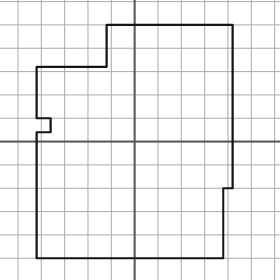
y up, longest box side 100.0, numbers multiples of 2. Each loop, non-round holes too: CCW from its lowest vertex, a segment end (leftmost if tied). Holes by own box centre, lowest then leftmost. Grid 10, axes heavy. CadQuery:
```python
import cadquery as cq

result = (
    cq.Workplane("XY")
    .moveTo(-42.0, -50.0)
    .lineTo(38.0, -50.0)
    .lineTo(38.0, -20.0)
    .lineTo(42.0, -20.0)
    .lineTo(42.0, 50.0)
    .lineTo(-12.0, 50.0)
    .lineTo(-12.0, 32.0)
    .lineTo(-42.0, 32.0)
    .lineTo(-42.0, 10.0)
    .lineTo(-36.0, 10.0)
    .lineTo(-36.0, 4.0)
    .lineTo(-42.0, 4.0)
    .close()
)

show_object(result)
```